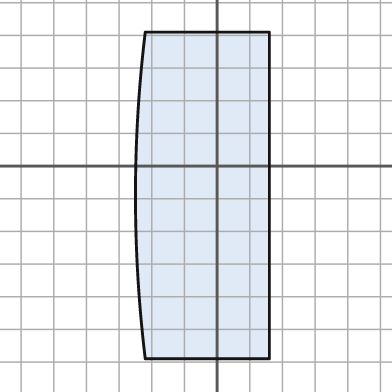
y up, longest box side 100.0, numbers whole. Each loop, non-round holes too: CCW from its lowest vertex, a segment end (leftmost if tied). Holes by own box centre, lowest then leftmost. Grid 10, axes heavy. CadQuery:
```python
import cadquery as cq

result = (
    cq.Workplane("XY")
    .moveTo(-22.0, -59.0)
    .lineTo(16.0, -59.0)
    .lineTo(16.0, 41.0)
    .lineTo(-22.0, 41.0)
    .threePointArc((-25.0, -9.0), (-22.0, -59.0))
    .close()
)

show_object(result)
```